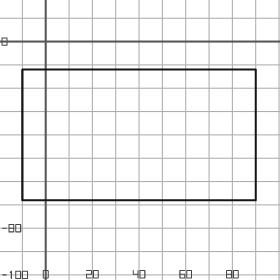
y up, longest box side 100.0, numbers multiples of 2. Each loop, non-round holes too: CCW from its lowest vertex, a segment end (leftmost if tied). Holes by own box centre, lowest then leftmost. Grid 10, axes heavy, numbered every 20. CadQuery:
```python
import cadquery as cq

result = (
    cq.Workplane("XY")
    .moveTo(-10.0, -68.0)
    .lineTo(90.0, -68.0)
    .lineTo(90.0, -12.0)
    .lineTo(-10.0, -12.0)
    .close()
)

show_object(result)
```